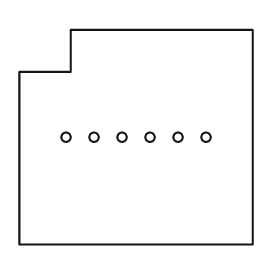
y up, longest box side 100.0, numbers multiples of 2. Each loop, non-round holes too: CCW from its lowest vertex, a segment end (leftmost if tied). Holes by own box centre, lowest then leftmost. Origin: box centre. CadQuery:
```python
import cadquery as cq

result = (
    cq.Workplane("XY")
    .moveTo(-50.0, -46.0)
    .lineTo(50.0, -46.0)
    .lineTo(50.0, 46.0)
    .lineTo(-28.0, 46.0)
    .lineTo(-28.0, 28.0)
    .lineTo(-50.0, 28.0)
    .close()
    .moveTo(-30.0, 0.0)
    .circle(2.0)
    .moveTo(-18.0, 0.0)
    .circle(2.0)
    .moveTo(-6.0, 0.0)
    .circle(2.0)
    .moveTo(6.0, 0.0)
    .circle(2.0)
    .moveTo(18.0, 0.0)
    .circle(2.0)
    .moveTo(30.0, 0.0)
    .circle(2.0)
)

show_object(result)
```